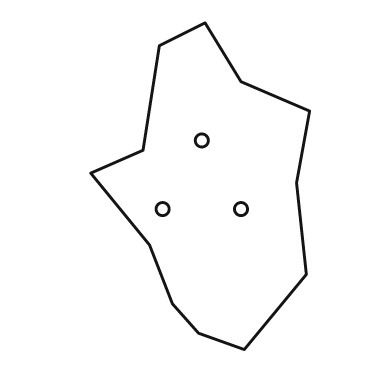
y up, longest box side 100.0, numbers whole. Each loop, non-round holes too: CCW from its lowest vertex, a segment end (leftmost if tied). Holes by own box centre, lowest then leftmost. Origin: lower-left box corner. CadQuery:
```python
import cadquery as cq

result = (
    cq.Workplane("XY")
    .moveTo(47.0, 0.0)
    .lineTo(66.0, 23.0)
    .lineTo(63.0, 51.0)
    .lineTo(67.0, 73.0)
    .lineTo(46.0, 82.0)
    .lineTo(35.0, 100.0)
    .lineTo(21.0, 93.0)
    .lineTo(16.0, 61.0)
    .lineTo(0.0, 54.0)
    .lineTo(18.0, 32.0)
    .lineTo(25.0, 14.0)
    .lineTo(33.0, 5.0)
    .close()
    .moveTo(22.0, 43.0)
    .circle(2.0)
    .moveTo(46.0, 43.0)
    .circle(2.0)
    .moveTo(34.0, 64.0)
    .circle(2.0)
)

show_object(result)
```